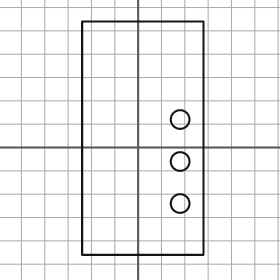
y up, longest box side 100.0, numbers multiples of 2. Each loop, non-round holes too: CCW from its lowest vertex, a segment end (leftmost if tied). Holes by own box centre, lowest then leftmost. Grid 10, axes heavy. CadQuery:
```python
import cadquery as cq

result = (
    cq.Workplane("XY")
    .moveTo(-24.0, -46.0)
    .lineTo(28.0, -46.0)
    .lineTo(28.0, 54.0)
    .lineTo(-24.0, 54.0)
    .close()
    .moveTo(18.0, -24.0)
    .circle(4.0)
    .moveTo(18.0, -6.0)
    .circle(4.0)
    .moveTo(18.0, 12.0)
    .circle(4.0)
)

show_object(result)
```